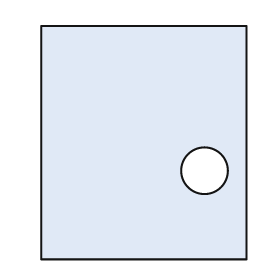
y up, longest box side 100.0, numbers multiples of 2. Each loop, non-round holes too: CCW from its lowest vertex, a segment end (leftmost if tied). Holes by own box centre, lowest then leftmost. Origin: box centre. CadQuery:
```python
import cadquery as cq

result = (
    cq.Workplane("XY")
    .moveTo(-44.0, -50.0)
    .lineTo(44.0, -50.0)
    .lineTo(44.0, 50.0)
    .lineTo(-44.0, 50.0)
    .close()
    .moveTo(26.0, -12.0)
    .circle(10.0)
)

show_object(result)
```